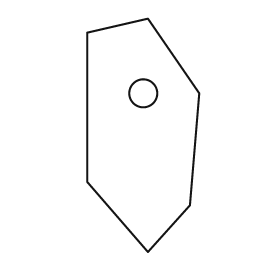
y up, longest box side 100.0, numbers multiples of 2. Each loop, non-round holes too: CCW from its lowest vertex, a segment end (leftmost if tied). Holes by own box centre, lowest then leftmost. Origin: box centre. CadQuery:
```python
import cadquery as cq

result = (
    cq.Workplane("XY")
    .moveTo(2.0, -50.0)
    .lineTo(20.0, -30.0)
    .lineTo(24.0, 18.0)
    .lineTo(2.0, 50.0)
    .lineTo(-24.0, 44.0)
    .lineTo(-24.0, -20.0)
    .close()
    .moveTo(0.0, 18.0)
    .circle(6.0)
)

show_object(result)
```